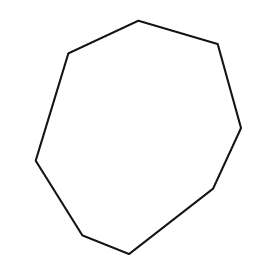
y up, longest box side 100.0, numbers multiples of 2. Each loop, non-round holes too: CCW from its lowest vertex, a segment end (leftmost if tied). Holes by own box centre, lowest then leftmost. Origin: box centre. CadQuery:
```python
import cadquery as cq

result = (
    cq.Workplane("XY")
    .moveTo(-4.0, -50.0)
    .lineTo(32.0, -22.0)
    .lineTo(44.0, 4.0)
    .lineTo(34.0, 40.0)
    .lineTo(0.0, 50.0)
    .lineTo(-30.0, 36.0)
    .lineTo(-44.0, -10.0)
    .lineTo(-24.0, -42.0)
    .close()
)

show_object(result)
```